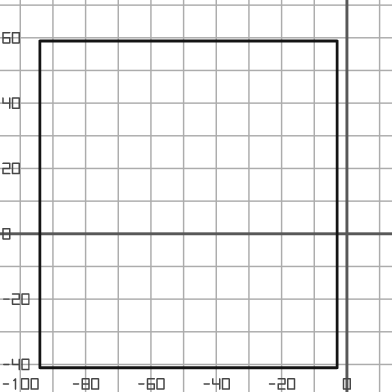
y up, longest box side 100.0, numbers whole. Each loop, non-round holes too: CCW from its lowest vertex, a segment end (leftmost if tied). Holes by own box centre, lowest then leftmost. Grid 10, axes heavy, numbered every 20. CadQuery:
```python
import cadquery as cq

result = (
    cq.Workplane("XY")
    .moveTo(-94.0, -41.0)
    .lineTo(-3.0, -41.0)
    .lineTo(-3.0, 59.0)
    .lineTo(-94.0, 59.0)
    .close()
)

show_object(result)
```